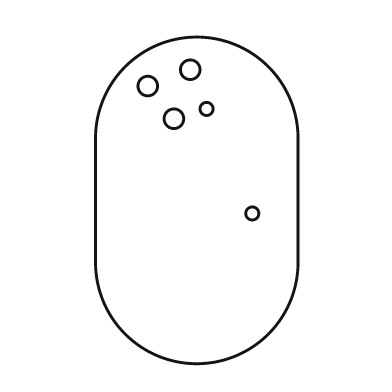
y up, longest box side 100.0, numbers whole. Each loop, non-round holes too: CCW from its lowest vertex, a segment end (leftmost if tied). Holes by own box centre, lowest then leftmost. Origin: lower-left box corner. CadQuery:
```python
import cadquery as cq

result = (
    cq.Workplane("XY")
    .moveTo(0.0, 31.0)
    .threePointArc((31.0, 0.0), (62.0, 31.0))
    .lineTo(62.0, 69.0)
    .threePointArc((31.0, 100.0), (0.0, 69.0))
    .close()
    .moveTo(48.0, 46.0)
    .circle(2.0)
    .moveTo(24.0, 75.0)
    .circle(3.0)
    .moveTo(34.0, 78.0)
    .circle(2.0)
    .moveTo(16.0, 85.0)
    .circle(3.0)
    .moveTo(29.0, 90.0)
    .circle(3.0)
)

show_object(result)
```